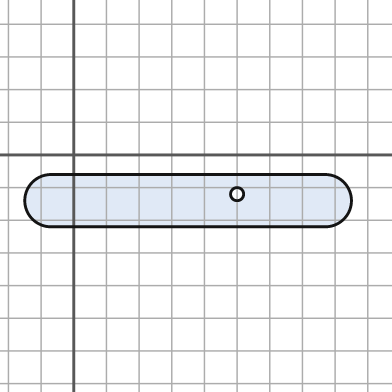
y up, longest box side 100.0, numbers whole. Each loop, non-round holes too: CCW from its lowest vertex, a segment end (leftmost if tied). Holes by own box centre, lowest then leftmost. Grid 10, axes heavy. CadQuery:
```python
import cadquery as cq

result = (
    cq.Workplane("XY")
    .moveTo(-7.0, -22.0)
    .lineTo(77.0, -22.0)
    .threePointArc((85.0, -14.0), (77.0, -6.0))
    .lineTo(-7.0, -6.0)
    .threePointArc((-15.0, -14.0), (-7.0, -22.0))
    .close()
    .moveTo(50.0, -12.0)
    .circle(2.0)
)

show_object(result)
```